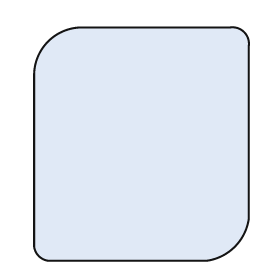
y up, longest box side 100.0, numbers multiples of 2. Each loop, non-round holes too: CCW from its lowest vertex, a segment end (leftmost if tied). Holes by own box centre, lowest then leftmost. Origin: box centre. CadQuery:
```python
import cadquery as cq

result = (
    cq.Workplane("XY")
    .moveTo(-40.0, -50.0)
    .lineTo(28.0, -50.0)
    .threePointArc((40.0, -44.0), (46.0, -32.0))
    .lineTo(46.0, 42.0)
    .threePointArc((44.0, 48.0), (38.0, 50.0))
    .lineTo(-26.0, 50.0)
    .threePointArc((-40.0, 44.0), (-46.0, 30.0))
    .lineTo(-46.0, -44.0)
    .threePointArc((-44.0, -48.0), (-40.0, -50.0))
    .close()
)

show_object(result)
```